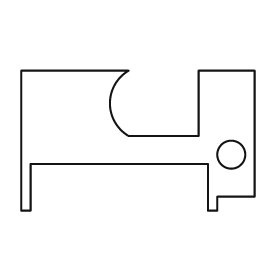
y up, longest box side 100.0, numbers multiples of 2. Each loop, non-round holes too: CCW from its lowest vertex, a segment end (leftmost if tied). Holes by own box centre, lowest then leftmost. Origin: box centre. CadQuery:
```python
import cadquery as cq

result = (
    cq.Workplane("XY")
    .moveTo(-50.0, -30.0)
    .lineTo(-46.0, -30.0)
    .lineTo(-46.0, -10.0)
    .lineTo(30.0, -10.0)
    .lineTo(30.0, -30.0)
    .lineTo(34.0, -30.0)
    .lineTo(34.0, -24.0)
    .lineTo(50.0, -24.0)
    .lineTo(50.0, 30.0)
    .lineTo(26.0, 30.0)
    .lineTo(26.0, 2.0)
    .lineTo(-4.0, 2.0)
    .threePointArc((-12.0, 16.0), (-4.0, 30.0))
    .lineTo(-50.0, 30.0)
    .close()
    .moveTo(40.0, -6.0)
    .circle(6.0)
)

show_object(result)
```